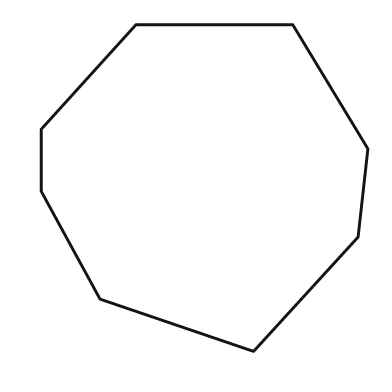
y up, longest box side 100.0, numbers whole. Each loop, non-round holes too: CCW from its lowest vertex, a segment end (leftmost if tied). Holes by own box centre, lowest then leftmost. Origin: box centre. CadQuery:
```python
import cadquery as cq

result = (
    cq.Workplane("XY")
    .moveTo(15.0, -50.0)
    .lineTo(47.0, -15.0)
    .lineTo(50.0, 12.0)
    .lineTo(27.0, 50.0)
    .lineTo(-21.0, 50.0)
    .lineTo(-50.0, 18.0)
    .lineTo(-50.0, -1.0)
    .lineTo(-32.0, -34.0)
    .close()
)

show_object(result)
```